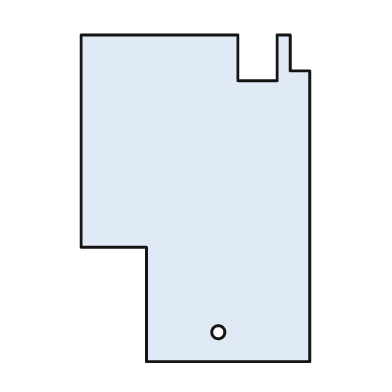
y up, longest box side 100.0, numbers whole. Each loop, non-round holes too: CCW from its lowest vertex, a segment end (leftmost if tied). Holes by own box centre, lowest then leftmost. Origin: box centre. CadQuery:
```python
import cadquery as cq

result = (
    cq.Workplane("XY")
    .moveTo(-15.0, -50.0)
    .lineTo(35.0, -50.0)
    .lineTo(35.0, 39.0)
    .lineTo(29.0, 39.0)
    .lineTo(29.0, 50.0)
    .lineTo(25.0, 50.0)
    .lineTo(25.0, 36.0)
    .lineTo(13.0, 36.0)
    .lineTo(13.0, 50.0)
    .lineTo(-35.0, 50.0)
    .lineTo(-35.0, -15.0)
    .lineTo(-15.0, -15.0)
    .close()
    .moveTo(7.0, -41.0)
    .circle(2.0)
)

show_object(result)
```